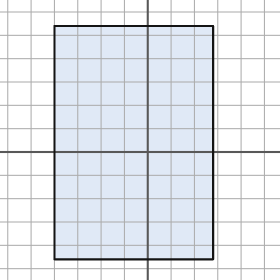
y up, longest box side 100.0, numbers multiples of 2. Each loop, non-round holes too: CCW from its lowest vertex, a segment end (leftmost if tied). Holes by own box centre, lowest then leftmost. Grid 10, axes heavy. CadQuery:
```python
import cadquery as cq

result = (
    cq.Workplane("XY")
    .moveTo(-40.0, -46.0)
    .lineTo(28.0, -46.0)
    .lineTo(28.0, 54.0)
    .lineTo(-40.0, 54.0)
    .close()
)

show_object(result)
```